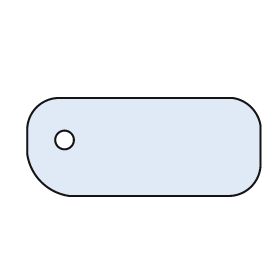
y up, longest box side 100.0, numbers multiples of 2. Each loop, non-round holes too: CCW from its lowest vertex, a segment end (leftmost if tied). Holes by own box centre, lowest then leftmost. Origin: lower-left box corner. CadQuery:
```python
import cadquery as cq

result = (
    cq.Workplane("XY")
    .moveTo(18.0, 0.0)
    .lineTo(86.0, 0.0)
    .threePointArc((96.0, 4.0), (100.0, 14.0))
    .lineTo(100.0, 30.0)
    .threePointArc((96.0, 38.0), (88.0, 42.0))
    .lineTo(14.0, 42.0)
    .threePointArc((4.0, 38.0), (0.0, 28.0))
    .lineTo(0.0, 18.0)
    .threePointArc((6.0, 6.0), (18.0, 0.0))
    .close()
    .moveTo(16.0, 24.0)
    .circle(4.0)
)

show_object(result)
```